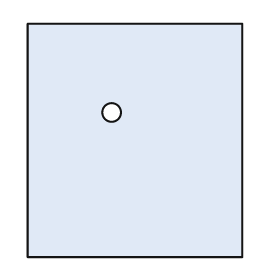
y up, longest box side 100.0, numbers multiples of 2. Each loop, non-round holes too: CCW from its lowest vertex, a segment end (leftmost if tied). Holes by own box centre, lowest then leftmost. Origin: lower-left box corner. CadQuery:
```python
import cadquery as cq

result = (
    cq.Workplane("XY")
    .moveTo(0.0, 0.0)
    .lineTo(92.0, 0.0)
    .lineTo(92.0, 100.0)
    .lineTo(0.0, 100.0)
    .close()
    .moveTo(36.0, 62.0)
    .circle(4.0)
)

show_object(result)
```